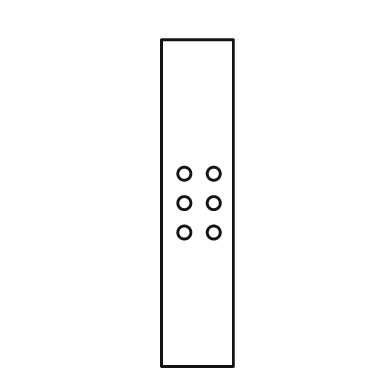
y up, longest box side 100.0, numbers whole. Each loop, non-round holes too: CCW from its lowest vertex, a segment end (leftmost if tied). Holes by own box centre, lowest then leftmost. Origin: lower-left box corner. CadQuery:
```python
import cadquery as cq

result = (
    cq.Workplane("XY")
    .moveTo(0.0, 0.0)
    .lineTo(22.0, 0.0)
    .lineTo(22.0, 100.0)
    .lineTo(0.0, 100.0)
    .close()
    .moveTo(7.0, 41.0)
    .circle(2.0)
    .moveTo(16.0, 41.0)
    .circle(2.0)
    .moveTo(7.0, 50.0)
    .circle(2.0)
    .moveTo(16.0, 50.0)
    .circle(2.0)
    .moveTo(7.0, 59.0)
    .circle(2.0)
    .moveTo(16.0, 59.0)
    .circle(2.0)
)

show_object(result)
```